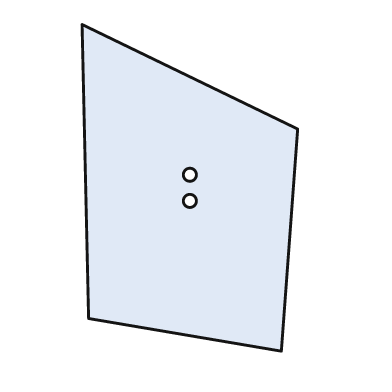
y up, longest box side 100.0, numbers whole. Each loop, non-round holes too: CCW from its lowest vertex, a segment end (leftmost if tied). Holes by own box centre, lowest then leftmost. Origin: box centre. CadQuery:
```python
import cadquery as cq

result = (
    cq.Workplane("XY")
    .moveTo(28.0, -50.0)
    .lineTo(33.0, 18.0)
    .lineTo(-33.0, 50.0)
    .lineTo(-31.0, -40.0)
    .close()
    .moveTo(0.0, -4.0)
    .circle(2.0)
    .moveTo(0.0, 4.0)
    .circle(2.0)
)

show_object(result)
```